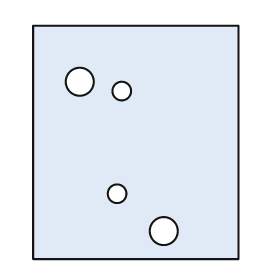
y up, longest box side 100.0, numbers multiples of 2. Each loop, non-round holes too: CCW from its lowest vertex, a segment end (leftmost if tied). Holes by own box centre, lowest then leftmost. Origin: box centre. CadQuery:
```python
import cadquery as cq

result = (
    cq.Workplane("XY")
    .moveTo(-44.0, -50.0)
    .lineTo(44.0, -50.0)
    .lineTo(44.0, 50.0)
    .lineTo(-44.0, 50.0)
    .close()
    .moveTo(12.0, -38.0)
    .circle(6.0)
    .moveTo(-8.0, -22.0)
    .circle(4.0)
    .moveTo(-6.0, 22.0)
    .circle(4.0)
    .moveTo(-24.0, 26.0)
    .circle(6.0)
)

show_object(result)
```